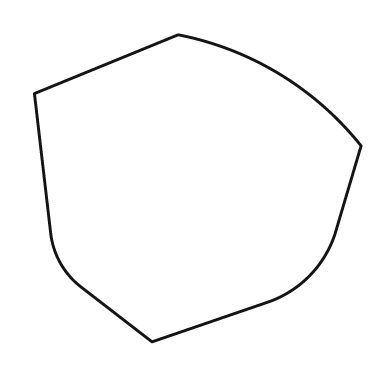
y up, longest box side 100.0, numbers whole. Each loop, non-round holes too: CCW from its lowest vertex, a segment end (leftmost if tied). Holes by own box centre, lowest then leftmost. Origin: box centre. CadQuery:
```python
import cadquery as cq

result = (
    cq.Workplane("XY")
    .moveTo(-14.0, -47.0)
    .lineTo(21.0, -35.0)
    .threePointArc((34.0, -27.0), (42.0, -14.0))
    .lineTo(50.0, 13.0)
    .threePointArc((25.0, 35.0), (-6.0, 47.0))
    .lineTo(-50.0, 29.0)
    .lineTo(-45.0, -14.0)
    .threePointArc((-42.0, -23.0), (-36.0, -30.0))
    .close()
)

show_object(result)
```